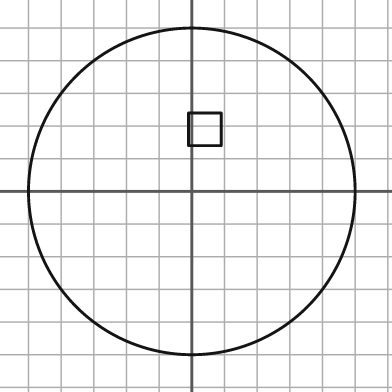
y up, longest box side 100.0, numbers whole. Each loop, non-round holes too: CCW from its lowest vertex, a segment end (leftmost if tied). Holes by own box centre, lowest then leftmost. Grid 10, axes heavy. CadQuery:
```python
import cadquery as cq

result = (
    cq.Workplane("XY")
    .moveTo(0.0, 0.0)
    .circle(50.0)
    .moveTo(-1.0, 14.0)
    .lineTo(9.0, 14.0)
    .lineTo(9.0, 24.0)
    .lineTo(-1.0, 24.0)
    .close()
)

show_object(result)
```